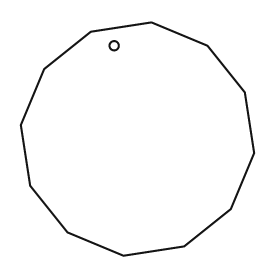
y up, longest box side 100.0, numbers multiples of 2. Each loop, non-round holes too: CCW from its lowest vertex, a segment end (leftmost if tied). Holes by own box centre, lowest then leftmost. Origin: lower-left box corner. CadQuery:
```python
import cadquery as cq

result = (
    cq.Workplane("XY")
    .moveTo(44.0, 0.0)
    .lineTo(70.0, 4.0)
    .lineTo(90.0, 20.0)
    .lineTo(100.0, 44.0)
    .lineTo(96.0, 70.0)
    .lineTo(80.0, 90.0)
    .lineTo(56.0, 100.0)
    .lineTo(30.0, 96.0)
    .lineTo(10.0, 80.0)
    .lineTo(0.0, 56.0)
    .lineTo(4.0, 30.0)
    .lineTo(20.0, 10.0)
    .close()
    .moveTo(40.0, 90.0)
    .circle(2.0)
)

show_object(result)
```